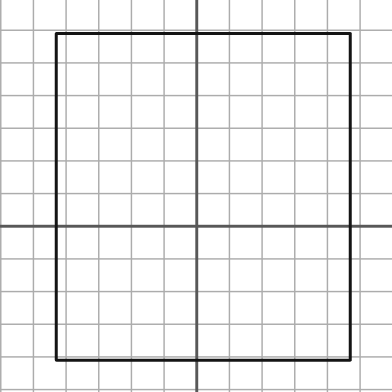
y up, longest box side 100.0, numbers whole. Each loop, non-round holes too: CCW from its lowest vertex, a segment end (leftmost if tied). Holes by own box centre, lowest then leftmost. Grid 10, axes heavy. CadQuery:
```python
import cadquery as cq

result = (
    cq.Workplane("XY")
    .moveTo(-43.0, -41.0)
    .lineTo(47.0, -41.0)
    .lineTo(47.0, 59.0)
    .lineTo(-43.0, 59.0)
    .close()
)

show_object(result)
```